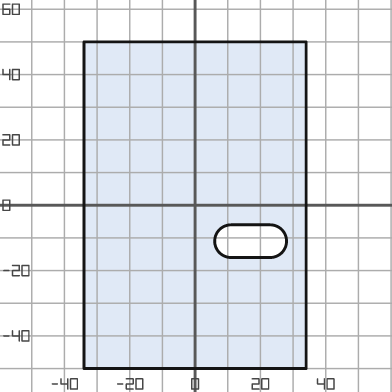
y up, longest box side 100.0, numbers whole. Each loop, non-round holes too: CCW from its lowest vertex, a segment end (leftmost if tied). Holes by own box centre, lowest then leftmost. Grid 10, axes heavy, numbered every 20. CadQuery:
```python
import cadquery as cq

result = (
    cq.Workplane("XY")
    .moveTo(-34.0, -50.0)
    .lineTo(34.0, -50.0)
    .lineTo(34.0, 50.0)
    .lineTo(-34.0, 50.0)
    .close()
    .moveTo(11.0, -16.0)
    .lineTo(23.0, -16.0)
    .threePointArc((28.0, -11.0), (23.0, -6.0))
    .lineTo(11.0, -6.0)
    .threePointArc((6.0, -11.0), (11.0, -16.0))
    .close()
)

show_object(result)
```